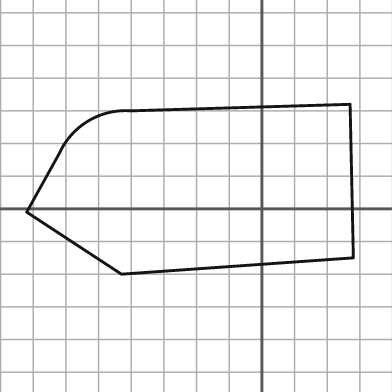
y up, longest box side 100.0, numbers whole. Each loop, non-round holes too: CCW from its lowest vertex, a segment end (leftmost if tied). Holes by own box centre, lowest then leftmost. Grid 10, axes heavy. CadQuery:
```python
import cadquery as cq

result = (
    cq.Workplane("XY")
    .moveTo(-43.0, -20.0)
    .lineTo(28.0, -15.0)
    .lineTo(27.0, 32.0)
    .lineTo(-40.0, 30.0)
    .threePointArc((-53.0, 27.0), (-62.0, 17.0))
    .lineTo(-72.0, -1.0)
    .close()
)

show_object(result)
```